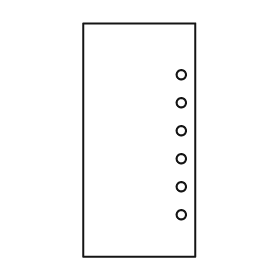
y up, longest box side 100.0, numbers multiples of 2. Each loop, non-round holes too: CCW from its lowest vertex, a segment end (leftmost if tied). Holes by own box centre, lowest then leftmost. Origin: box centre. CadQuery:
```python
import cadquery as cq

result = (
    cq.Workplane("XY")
    .moveTo(-24.0, -50.0)
    .lineTo(24.0, -50.0)
    .lineTo(24.0, 50.0)
    .lineTo(-24.0, 50.0)
    .close()
    .moveTo(18.0, -32.0)
    .circle(2.0)
    .moveTo(18.0, -20.0)
    .circle(2.0)
    .moveTo(18.0, -8.0)
    .circle(2.0)
    .moveTo(18.0, 4.0)
    .circle(2.0)
    .moveTo(18.0, 16.0)
    .circle(2.0)
    .moveTo(18.0, 28.0)
    .circle(2.0)
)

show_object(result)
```